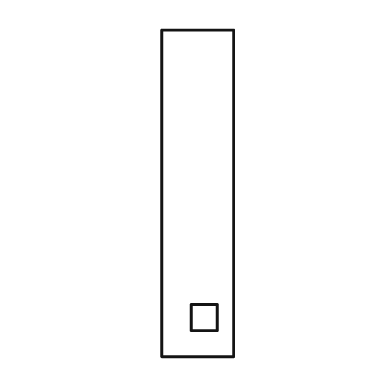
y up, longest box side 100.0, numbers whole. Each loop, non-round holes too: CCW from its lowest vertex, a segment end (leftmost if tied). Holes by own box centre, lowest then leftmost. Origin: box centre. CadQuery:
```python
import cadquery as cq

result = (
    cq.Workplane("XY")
    .moveTo(-11.0, -50.0)
    .lineTo(11.0, -50.0)
    .lineTo(11.0, 50.0)
    .lineTo(-11.0, 50.0)
    .close()
    .moveTo(-2.0, -42.0)
    .lineTo(6.0, -42.0)
    .lineTo(6.0, -34.0)
    .lineTo(-2.0, -34.0)
    .close()
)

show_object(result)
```